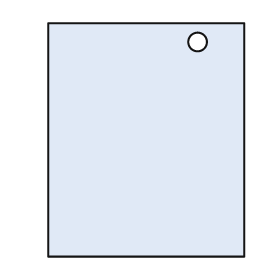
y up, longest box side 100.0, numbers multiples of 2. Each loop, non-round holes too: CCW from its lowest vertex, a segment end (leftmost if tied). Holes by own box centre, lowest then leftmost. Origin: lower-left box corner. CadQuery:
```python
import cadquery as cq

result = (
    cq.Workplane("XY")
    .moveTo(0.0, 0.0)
    .lineTo(84.0, 0.0)
    .lineTo(84.0, 100.0)
    .lineTo(0.0, 100.0)
    .close()
    .moveTo(64.0, 92.0)
    .circle(4.0)
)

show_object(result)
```